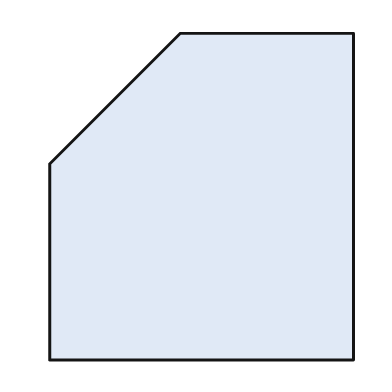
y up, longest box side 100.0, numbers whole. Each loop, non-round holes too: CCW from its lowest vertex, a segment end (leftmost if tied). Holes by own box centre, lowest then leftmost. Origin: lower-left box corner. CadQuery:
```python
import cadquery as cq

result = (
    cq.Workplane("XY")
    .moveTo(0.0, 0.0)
    .lineTo(93.0, 0.0)
    .lineTo(93.0, 100.0)
    .lineTo(40.0, 100.0)
    .lineTo(0.0, 60.0)
    .close()
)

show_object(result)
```